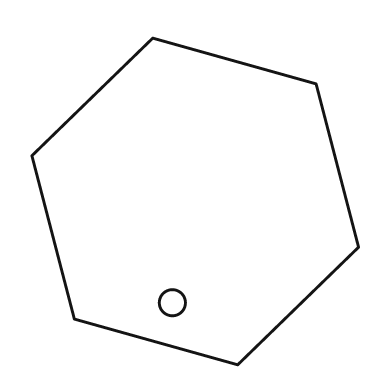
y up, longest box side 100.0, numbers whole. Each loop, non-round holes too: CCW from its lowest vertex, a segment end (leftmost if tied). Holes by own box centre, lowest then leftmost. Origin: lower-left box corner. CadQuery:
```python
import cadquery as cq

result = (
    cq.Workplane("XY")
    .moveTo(63.0, 0.0)
    .lineTo(100.0, 36.0)
    .lineTo(87.0, 86.0)
    .lineTo(37.0, 100.0)
    .lineTo(0.0, 64.0)
    .lineTo(13.0, 14.0)
    .close()
    .moveTo(43.0, 19.0)
    .circle(4.0)
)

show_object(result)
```